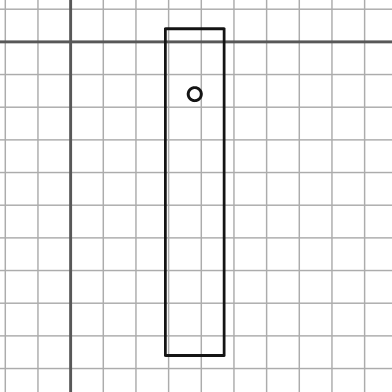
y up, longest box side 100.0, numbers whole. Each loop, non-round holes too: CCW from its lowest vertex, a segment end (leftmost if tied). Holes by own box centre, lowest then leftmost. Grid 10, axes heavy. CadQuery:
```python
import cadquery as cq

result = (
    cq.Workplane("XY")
    .moveTo(29.0, -96.0)
    .lineTo(47.0, -96.0)
    .lineTo(47.0, 4.0)
    .lineTo(29.0, 4.0)
    .close()
    .moveTo(38.0, -16.0)
    .circle(2.0)
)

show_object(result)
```